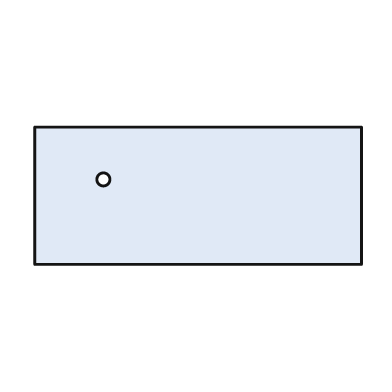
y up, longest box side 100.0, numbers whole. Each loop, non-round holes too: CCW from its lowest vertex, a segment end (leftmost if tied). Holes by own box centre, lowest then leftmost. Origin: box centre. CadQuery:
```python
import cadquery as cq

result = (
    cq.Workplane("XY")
    .moveTo(-50.0, -21.0)
    .lineTo(50.0, -21.0)
    .lineTo(50.0, 21.0)
    .lineTo(-50.0, 21.0)
    .close()
    .moveTo(-29.0, 5.0)
    .circle(2.0)
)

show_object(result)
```